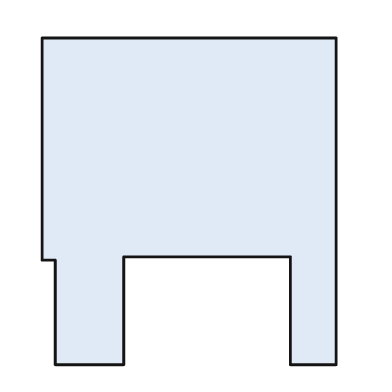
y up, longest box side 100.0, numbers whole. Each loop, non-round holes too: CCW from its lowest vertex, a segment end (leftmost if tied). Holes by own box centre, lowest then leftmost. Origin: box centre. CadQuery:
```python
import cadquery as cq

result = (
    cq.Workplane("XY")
    .moveTo(-41.0, -50.0)
    .lineTo(-20.0, -50.0)
    .lineTo(-20.0, -17.0)
    .lineTo(31.0, -17.0)
    .lineTo(31.0, -50.0)
    .lineTo(45.0, -50.0)
    .lineTo(45.0, 50.0)
    .lineTo(-45.0, 50.0)
    .lineTo(-45.0, -18.0)
    .lineTo(-41.0, -18.0)
    .close()
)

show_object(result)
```